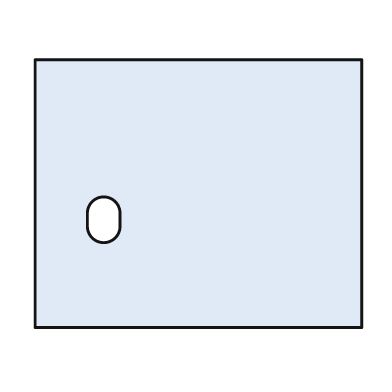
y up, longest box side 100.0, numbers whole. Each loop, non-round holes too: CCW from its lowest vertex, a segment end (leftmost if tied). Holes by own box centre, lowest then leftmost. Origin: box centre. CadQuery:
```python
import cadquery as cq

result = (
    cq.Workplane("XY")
    .moveTo(-50.0, -41.0)
    .lineTo(50.0, -41.0)
    .lineTo(50.0, 41.0)
    .lineTo(-50.0, 41.0)
    .close()
    .moveTo(-34.0, -10.0)
    .threePointArc((-29.0, -15.0), (-24.0, -10.0))
    .lineTo(-24.0, -6.0)
    .threePointArc((-29.0, -1.0), (-34.0, -6.0))
    .close()
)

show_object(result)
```